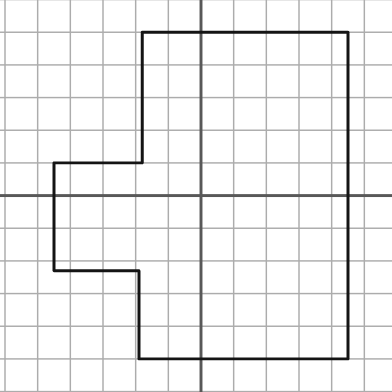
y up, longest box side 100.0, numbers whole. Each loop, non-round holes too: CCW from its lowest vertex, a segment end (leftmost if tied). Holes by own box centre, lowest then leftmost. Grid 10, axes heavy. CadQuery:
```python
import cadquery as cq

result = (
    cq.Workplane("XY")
    .moveTo(-19.0, -50.0)
    .lineTo(45.0, -50.0)
    .lineTo(45.0, 50.0)
    .lineTo(-18.0, 50.0)
    .lineTo(-18.0, 10.0)
    .lineTo(-45.0, 10.0)
    .lineTo(-45.0, -23.0)
    .lineTo(-19.0, -23.0)
    .close()
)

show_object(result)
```